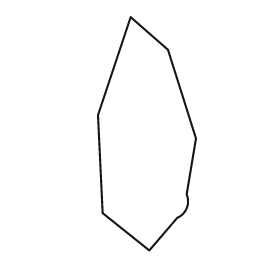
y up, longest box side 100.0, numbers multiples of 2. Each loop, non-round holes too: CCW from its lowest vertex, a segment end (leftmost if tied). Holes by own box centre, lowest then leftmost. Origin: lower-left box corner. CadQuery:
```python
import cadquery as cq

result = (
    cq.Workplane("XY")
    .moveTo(22.0, 0.0)
    .lineTo(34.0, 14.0)
    .threePointArc((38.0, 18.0), (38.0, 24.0))
    .lineTo(42.0, 48.0)
    .lineTo(30.0, 86.0)
    .lineTo(14.0, 100.0)
    .lineTo(0.0, 58.0)
    .lineTo(2.0, 16.0)
    .close()
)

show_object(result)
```